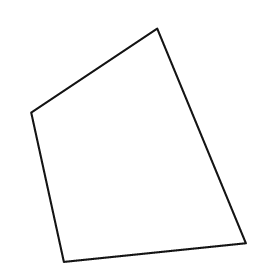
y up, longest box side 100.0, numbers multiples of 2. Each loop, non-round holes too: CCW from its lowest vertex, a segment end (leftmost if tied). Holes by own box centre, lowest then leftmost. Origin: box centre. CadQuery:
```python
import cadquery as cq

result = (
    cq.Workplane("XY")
    .moveTo(-32.0, -50.0)
    .lineTo(46.0, -42.0)
    .lineTo(8.0, 50.0)
    .lineTo(-46.0, 14.0)
    .close()
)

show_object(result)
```